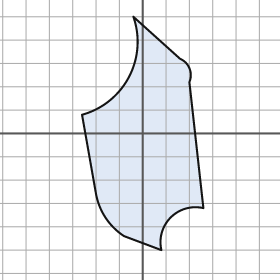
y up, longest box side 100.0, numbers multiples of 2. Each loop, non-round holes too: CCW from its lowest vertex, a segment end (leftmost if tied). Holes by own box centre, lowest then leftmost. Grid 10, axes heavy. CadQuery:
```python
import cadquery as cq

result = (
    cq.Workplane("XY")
    .moveTo(8.0, -50.0)
    .threePointArc((12.0, -36.0), (26.0, -32.0))
    .lineTo(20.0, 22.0)
    .threePointArc((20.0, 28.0), (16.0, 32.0))
    .lineTo(-4.0, 50.0)
    .threePointArc((-6.0, 24.0), (-26.0, 8.0))
    .lineTo(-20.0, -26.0)
    .threePointArc((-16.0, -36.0), (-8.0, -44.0))
    .close()
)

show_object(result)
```